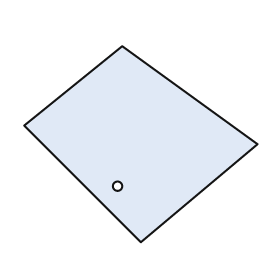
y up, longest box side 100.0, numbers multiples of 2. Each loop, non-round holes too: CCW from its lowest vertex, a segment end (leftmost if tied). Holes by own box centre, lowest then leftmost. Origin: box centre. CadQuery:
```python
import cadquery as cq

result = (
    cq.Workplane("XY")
    .moveTo(0.0, -42.0)
    .lineTo(50.0, 0.0)
    .lineTo(-8.0, 42.0)
    .lineTo(-50.0, 8.0)
    .close()
    .moveTo(-10.0, -18.0)
    .circle(2.0)
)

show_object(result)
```